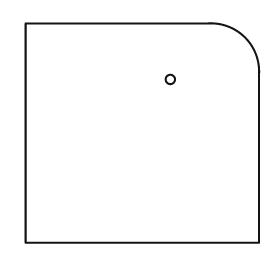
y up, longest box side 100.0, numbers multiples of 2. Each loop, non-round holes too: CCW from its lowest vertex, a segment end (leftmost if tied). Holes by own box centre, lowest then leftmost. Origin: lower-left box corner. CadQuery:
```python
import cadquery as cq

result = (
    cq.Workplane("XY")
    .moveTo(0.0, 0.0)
    .lineTo(100.0, 0.0)
    .lineTo(100.0, 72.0)
    .threePointArc((94.0, 88.0), (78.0, 94.0))
    .lineTo(0.0, 94.0)
    .close()
    .moveTo(62.0, 70.0)
    .circle(2.0)
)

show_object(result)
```